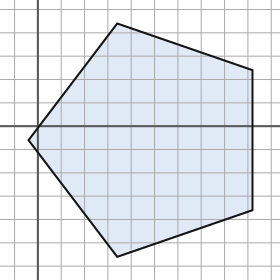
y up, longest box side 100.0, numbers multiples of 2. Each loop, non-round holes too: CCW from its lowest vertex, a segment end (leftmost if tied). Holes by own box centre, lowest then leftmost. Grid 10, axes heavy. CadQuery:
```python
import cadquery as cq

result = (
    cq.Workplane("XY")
    .moveTo(34.0, -56.0)
    .lineTo(92.0, -36.0)
    .lineTo(92.0, 24.0)
    .lineTo(34.0, 44.0)
    .lineTo(-4.0, -6.0)
    .close()
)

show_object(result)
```